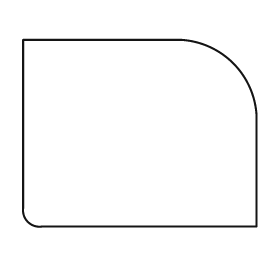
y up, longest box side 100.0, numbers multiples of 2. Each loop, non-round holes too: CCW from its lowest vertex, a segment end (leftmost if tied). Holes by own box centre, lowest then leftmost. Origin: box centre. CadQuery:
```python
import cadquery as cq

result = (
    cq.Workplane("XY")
    .moveTo(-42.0, -40.0)
    .lineTo(50.0, -40.0)
    .lineTo(50.0, 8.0)
    .threePointArc((40.0, 30.0), (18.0, 40.0))
    .lineTo(-50.0, 40.0)
    .lineTo(-50.0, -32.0)
    .threePointArc((-48.0, -38.0), (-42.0, -40.0))
    .close()
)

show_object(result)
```